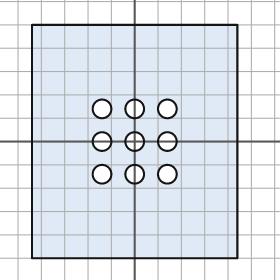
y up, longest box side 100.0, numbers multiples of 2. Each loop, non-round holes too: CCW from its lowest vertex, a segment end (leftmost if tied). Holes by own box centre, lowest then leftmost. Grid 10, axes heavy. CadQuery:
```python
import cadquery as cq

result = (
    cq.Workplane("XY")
    .moveTo(-44.0, -50.0)
    .lineTo(44.0, -50.0)
    .lineTo(44.0, 50.0)
    .lineTo(-44.0, 50.0)
    .close()
    .moveTo(-14.0, -14.0)
    .circle(4.0)
    .moveTo(0.0, -14.0)
    .circle(4.0)
    .moveTo(14.0, -14.0)
    .circle(4.0)
    .moveTo(-14.0, 0.0)
    .circle(4.0)
    .moveTo(0.0, 0.0)
    .circle(4.0)
    .moveTo(14.0, 0.0)
    .circle(4.0)
    .moveTo(-14.0, 14.0)
    .circle(4.0)
    .moveTo(0.0, 14.0)
    .circle(4.0)
    .moveTo(14.0, 14.0)
    .circle(4.0)
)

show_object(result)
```